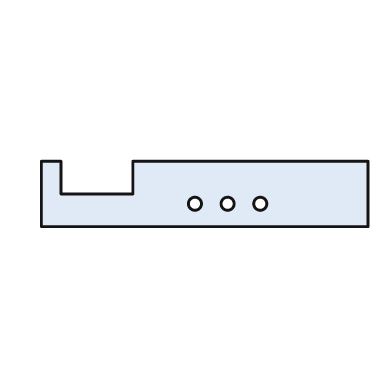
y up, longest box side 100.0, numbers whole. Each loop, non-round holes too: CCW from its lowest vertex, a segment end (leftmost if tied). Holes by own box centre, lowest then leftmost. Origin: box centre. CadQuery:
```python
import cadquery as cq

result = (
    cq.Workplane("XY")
    .moveTo(-50.0, -10.0)
    .lineTo(50.0, -10.0)
    .lineTo(50.0, 10.0)
    .lineTo(-22.0, 10.0)
    .lineTo(-22.0, 0.0)
    .lineTo(-44.0, 0.0)
    .lineTo(-44.0, 10.0)
    .lineTo(-50.0, 10.0)
    .close()
    .moveTo(-3.0, -3.0)
    .circle(2.0)
    .moveTo(7.0, -3.0)
    .circle(2.0)
    .moveTo(17.0, -3.0)
    .circle(2.0)
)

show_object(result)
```